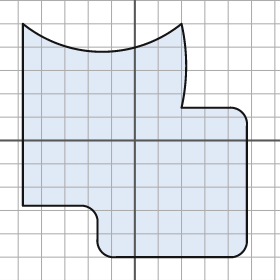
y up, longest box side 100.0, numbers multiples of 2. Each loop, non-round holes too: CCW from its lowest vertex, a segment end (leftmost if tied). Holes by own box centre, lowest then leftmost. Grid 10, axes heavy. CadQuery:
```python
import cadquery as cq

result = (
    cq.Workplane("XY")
    .moveTo(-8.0, -50.0)
    .lineTo(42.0, -50.0)
    .threePointArc((46.0, -48.0), (48.0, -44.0))
    .lineTo(48.0, 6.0)
    .threePointArc((46.0, 12.0), (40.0, 14.0))
    .lineTo(20.0, 14.0)
    .threePointArc((22.0, 32.0), (20.0, 50.0))
    .threePointArc((-14.0, 38.0), (-48.0, 50.0))
    .lineTo(-48.0, -28.0)
    .lineTo(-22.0, -28.0)
    .threePointArc((-18.0, -30.0), (-16.0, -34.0))
    .lineTo(-16.0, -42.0)
    .threePointArc((-14.0, -48.0), (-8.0, -50.0))
    .close()
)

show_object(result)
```